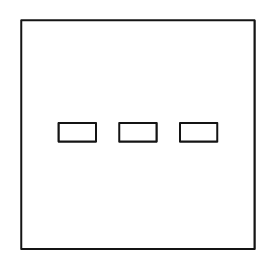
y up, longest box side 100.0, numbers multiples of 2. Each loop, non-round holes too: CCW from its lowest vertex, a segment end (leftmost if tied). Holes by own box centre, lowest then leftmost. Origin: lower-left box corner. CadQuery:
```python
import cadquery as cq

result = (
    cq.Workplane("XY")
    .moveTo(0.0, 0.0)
    .lineTo(100.0, 0.0)
    .lineTo(100.0, 98.0)
    .lineTo(0.0, 98.0)
    .close()
    .moveTo(16.0, 46.0)
    .lineTo(32.0, 46.0)
    .lineTo(32.0, 54.0)
    .lineTo(16.0, 54.0)
    .close()
    .moveTo(42.0, 46.0)
    .lineTo(58.0, 46.0)
    .lineTo(58.0, 54.0)
    .lineTo(42.0, 54.0)
    .close()
    .moveTo(68.0, 46.0)
    .lineTo(84.0, 46.0)
    .lineTo(84.0, 54.0)
    .lineTo(68.0, 54.0)
    .close()
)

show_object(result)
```